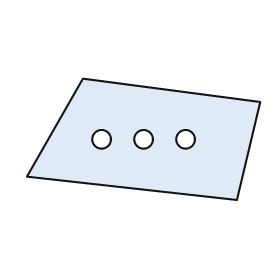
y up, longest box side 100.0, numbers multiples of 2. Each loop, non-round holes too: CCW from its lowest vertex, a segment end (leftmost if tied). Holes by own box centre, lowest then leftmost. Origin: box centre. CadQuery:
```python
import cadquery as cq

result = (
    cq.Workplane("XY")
    .moveTo(40.0, -26.0)
    .lineTo(50.0, 16.0)
    .lineTo(-26.0, 26.0)
    .lineTo(-50.0, -16.0)
    .close()
    .moveTo(-18.0, 0.0)
    .circle(4.0)
    .moveTo(0.0, 0.0)
    .circle(4.0)
    .moveTo(18.0, 0.0)
    .circle(4.0)
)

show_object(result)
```